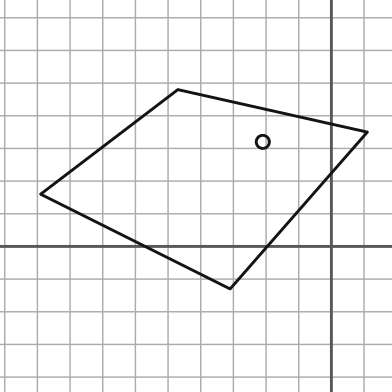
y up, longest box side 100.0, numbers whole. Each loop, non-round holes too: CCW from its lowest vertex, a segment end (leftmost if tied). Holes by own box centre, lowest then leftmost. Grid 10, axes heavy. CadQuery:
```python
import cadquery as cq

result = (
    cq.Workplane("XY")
    .moveTo(-31.0, -13.0)
    .lineTo(11.0, 35.0)
    .lineTo(-47.0, 48.0)
    .lineTo(-89.0, 16.0)
    .close()
    .moveTo(-21.0, 32.0)
    .circle(2.0)
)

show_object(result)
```